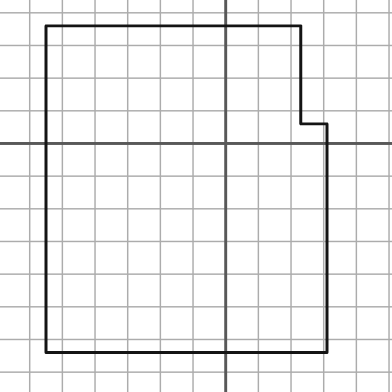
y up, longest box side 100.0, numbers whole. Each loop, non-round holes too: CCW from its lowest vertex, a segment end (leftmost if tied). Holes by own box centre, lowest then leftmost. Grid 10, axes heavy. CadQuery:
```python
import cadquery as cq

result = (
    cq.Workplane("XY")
    .moveTo(-55.0, -64.0)
    .lineTo(31.0, -64.0)
    .lineTo(31.0, 6.0)
    .lineTo(23.0, 6.0)
    .lineTo(23.0, 36.0)
    .lineTo(-55.0, 36.0)
    .close()
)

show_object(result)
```